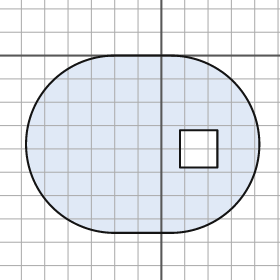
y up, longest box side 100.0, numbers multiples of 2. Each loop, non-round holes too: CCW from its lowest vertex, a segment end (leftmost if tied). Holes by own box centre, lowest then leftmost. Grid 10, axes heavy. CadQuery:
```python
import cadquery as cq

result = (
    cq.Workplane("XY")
    .moveTo(-20.0, -76.0)
    .lineTo(4.0, -76.0)
    .threePointArc((42.0, -38.0), (4.0, 0.0))
    .lineTo(-20.0, 0.0)
    .threePointArc((-58.0, -38.0), (-20.0, -76.0))
    .close()
    .moveTo(8.0, -48.0)
    .lineTo(24.0, -48.0)
    .lineTo(24.0, -32.0)
    .lineTo(8.0, -32.0)
    .close()
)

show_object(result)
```